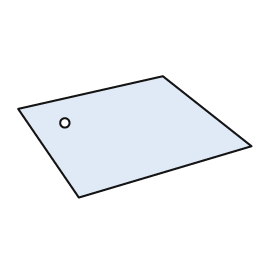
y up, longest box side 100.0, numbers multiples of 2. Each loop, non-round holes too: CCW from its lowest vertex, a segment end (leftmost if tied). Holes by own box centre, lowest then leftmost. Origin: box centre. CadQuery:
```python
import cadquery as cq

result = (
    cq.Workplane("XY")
    .moveTo(-24.0, -26.0)
    .lineTo(50.0, -4.0)
    .lineTo(12.0, 26.0)
    .lineTo(-50.0, 12.0)
    .close()
    .moveTo(-30.0, 6.0)
    .circle(2.0)
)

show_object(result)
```